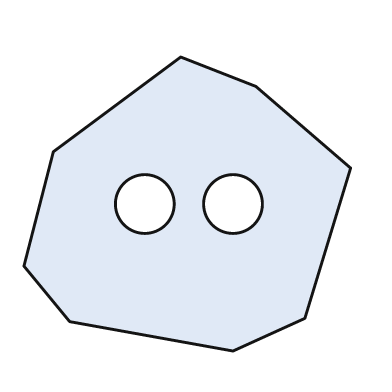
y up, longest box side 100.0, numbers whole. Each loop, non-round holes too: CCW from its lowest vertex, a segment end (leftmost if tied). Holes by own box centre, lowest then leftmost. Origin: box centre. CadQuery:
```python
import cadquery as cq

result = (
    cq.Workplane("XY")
    .moveTo(14.0, -45.0)
    .lineTo(36.0, -35.0)
    .lineTo(50.0, 11.0)
    .lineTo(21.0, 36.0)
    .lineTo(-2.0, 45.0)
    .lineTo(-41.0, 16.0)
    .lineTo(-50.0, -19.0)
    .lineTo(-36.0, -36.0)
    .close()
    .moveTo(-13.0, 0.0)
    .circle(9.0)
    .moveTo(14.0, 0.0)
    .circle(9.0)
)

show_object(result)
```